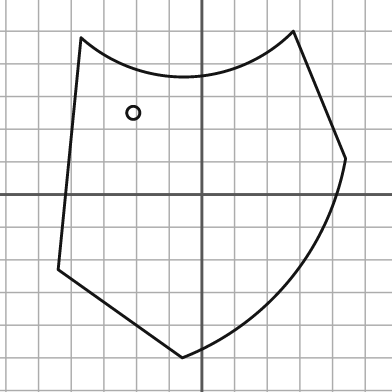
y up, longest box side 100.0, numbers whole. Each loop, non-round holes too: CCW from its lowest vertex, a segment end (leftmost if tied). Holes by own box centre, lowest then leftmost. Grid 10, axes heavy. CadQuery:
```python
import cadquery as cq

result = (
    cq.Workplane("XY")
    .moveTo(-6.0, -50.0)
    .threePointArc((27.0, -26.0), (44.0, 11.0))
    .lineTo(28.0, 50.0)
    .threePointArc((-4.0, 36.0), (-37.0, 48.0))
    .lineTo(-44.0, -23.0)
    .close()
    .moveTo(-21.0, 25.0)
    .circle(2.0)
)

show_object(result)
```